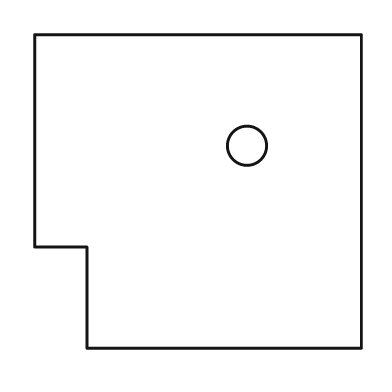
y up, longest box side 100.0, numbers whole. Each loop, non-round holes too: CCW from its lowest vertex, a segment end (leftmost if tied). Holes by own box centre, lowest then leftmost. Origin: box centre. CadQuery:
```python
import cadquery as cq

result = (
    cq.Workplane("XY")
    .moveTo(-34.0, -48.0)
    .lineTo(50.0, -48.0)
    .lineTo(50.0, 48.0)
    .lineTo(-50.0, 48.0)
    .lineTo(-50.0, -17.0)
    .lineTo(-34.0, -17.0)
    .close()
    .moveTo(15.0, 14.0)
    .circle(6.0)
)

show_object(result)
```